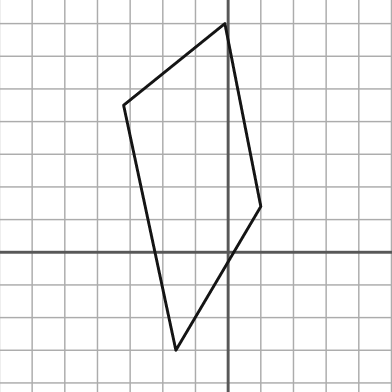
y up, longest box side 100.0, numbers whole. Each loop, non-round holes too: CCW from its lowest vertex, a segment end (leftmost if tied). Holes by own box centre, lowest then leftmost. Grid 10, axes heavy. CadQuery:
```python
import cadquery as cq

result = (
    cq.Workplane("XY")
    .moveTo(-16.0, -30.0)
    .lineTo(10.0, 14.0)
    .lineTo(-1.0, 70.0)
    .lineTo(-32.0, 45.0)
    .close()
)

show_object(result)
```